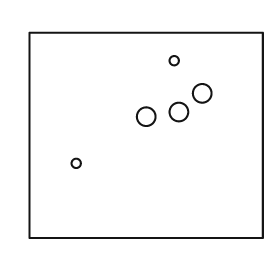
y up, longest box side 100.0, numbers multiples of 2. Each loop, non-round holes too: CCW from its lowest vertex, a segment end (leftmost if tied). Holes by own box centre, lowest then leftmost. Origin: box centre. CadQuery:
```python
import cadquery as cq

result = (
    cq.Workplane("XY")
    .moveTo(-50.0, -44.0)
    .lineTo(50.0, -44.0)
    .lineTo(50.0, 44.0)
    .lineTo(-50.0, 44.0)
    .close()
    .moveTo(-30.0, -12.0)
    .circle(2.0)
    .moveTo(0.0, 8.0)
    .circle(4.0)
    .moveTo(14.0, 10.0)
    .circle(4.0)
    .moveTo(24.0, 18.0)
    .circle(4.0)
    .moveTo(12.0, 32.0)
    .circle(2.0)
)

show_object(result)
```